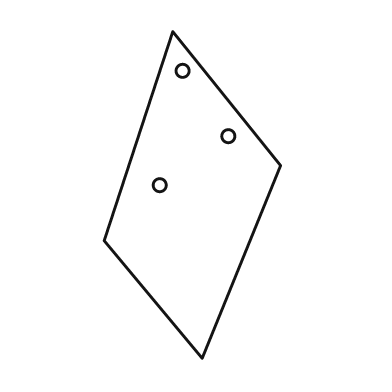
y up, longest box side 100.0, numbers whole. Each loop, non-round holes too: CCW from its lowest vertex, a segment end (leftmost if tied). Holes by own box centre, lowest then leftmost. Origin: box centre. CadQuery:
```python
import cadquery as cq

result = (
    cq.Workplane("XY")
    .moveTo(3.0, -50.0)
    .lineTo(27.0, 9.0)
    .lineTo(-6.0, 50.0)
    .lineTo(-27.0, -14.0)
    .close()
    .moveTo(-10.0, 3.0)
    .circle(2.0)
    .moveTo(11.0, 18.0)
    .circle(2.0)
    .moveTo(-3.0, 38.0)
    .circle(2.0)
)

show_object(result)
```